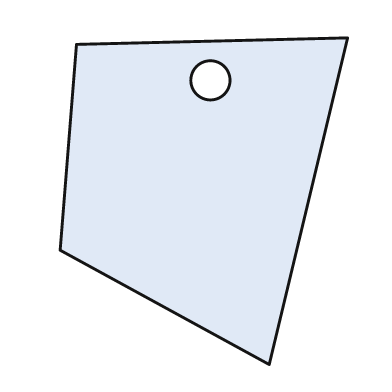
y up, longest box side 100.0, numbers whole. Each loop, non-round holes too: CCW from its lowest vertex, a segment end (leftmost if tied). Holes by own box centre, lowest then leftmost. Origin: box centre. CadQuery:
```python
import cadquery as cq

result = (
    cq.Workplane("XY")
    .moveTo(20.0, -50.0)
    .lineTo(44.0, 50.0)
    .lineTo(-39.0, 48.0)
    .lineTo(-44.0, -15.0)
    .close()
    .moveTo(2.0, 37.0)
    .circle(6.0)
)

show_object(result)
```